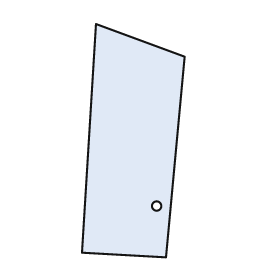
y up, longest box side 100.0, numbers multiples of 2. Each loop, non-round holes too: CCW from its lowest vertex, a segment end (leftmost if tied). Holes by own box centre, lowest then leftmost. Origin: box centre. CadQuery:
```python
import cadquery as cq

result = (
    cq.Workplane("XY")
    .moveTo(14.0, -50.0)
    .lineTo(22.0, 36.0)
    .lineTo(-16.0, 50.0)
    .lineTo(-22.0, -48.0)
    .close()
    .moveTo(10.0, -28.0)
    .circle(2.0)
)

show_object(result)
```